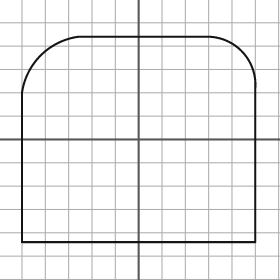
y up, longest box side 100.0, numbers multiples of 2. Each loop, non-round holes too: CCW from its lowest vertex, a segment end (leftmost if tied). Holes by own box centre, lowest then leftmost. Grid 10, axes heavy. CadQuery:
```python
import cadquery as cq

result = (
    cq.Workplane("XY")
    .moveTo(-50.0, -44.0)
    .lineTo(50.0, -44.0)
    .lineTo(50.0, 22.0)
    .threePointArc((44.0, 38.0), (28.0, 44.0))
    .lineTo(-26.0, 44.0)
    .threePointArc((-42.0, 36.0), (-50.0, 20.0))
    .close()
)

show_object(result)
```